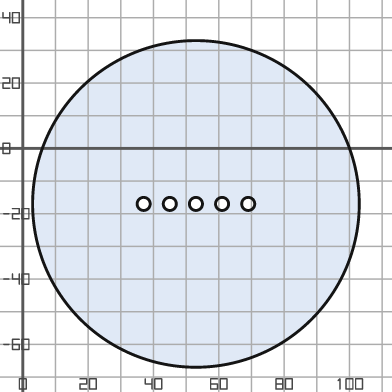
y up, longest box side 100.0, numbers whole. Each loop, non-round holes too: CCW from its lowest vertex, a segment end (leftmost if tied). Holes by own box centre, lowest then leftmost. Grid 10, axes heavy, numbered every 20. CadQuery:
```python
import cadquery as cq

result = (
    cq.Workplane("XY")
    .moveTo(53.0, -17.0)
    .circle(50.0)
    .moveTo(37.0, -17.0)
    .circle(2.0)
    .moveTo(45.0, -17.0)
    .circle(2.0)
    .moveTo(53.0, -17.0)
    .circle(2.0)
    .moveTo(61.0, -17.0)
    .circle(2.0)
    .moveTo(69.0, -17.0)
    .circle(2.0)
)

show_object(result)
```